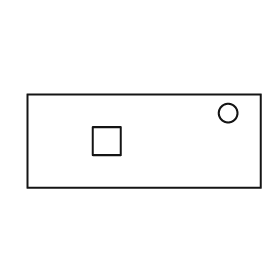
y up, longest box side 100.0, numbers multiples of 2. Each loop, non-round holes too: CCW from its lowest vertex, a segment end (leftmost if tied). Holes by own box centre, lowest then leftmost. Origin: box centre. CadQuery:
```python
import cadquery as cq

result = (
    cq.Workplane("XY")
    .moveTo(-50.0, -20.0)
    .lineTo(50.0, -20.0)
    .lineTo(50.0, 20.0)
    .lineTo(-50.0, 20.0)
    .close()
    .moveTo(-22.0, -6.0)
    .lineTo(-10.0, -6.0)
    .lineTo(-10.0, 6.0)
    .lineTo(-22.0, 6.0)
    .close()
    .moveTo(36.0, 12.0)
    .circle(4.0)
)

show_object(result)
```